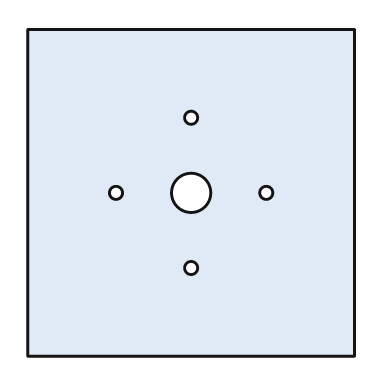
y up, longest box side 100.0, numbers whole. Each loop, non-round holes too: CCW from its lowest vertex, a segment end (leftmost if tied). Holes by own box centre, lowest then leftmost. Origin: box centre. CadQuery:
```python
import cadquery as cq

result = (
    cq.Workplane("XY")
    .moveTo(-50.0, -50.0)
    .lineTo(50.0, -50.0)
    .lineTo(50.0, 50.0)
    .lineTo(-50.0, 50.0)
    .close()
    .moveTo(0.0, -23.0)
    .circle(2.0)
    .moveTo(-23.0, 0.0)
    .circle(2.0)
    .moveTo(0.0, 0.0)
    .circle(6.0)
    .moveTo(23.0, 0.0)
    .circle(2.0)
    .moveTo(0.0, 23.0)
    .circle(2.0)
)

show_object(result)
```